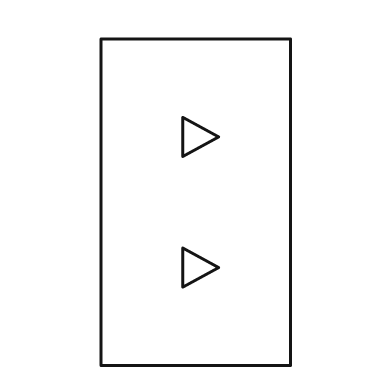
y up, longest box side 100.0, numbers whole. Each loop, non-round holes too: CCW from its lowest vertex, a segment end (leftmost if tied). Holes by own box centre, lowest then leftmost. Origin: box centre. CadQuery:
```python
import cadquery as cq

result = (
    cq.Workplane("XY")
    .moveTo(-29.0, -50.0)
    .lineTo(29.0, -50.0)
    .lineTo(29.0, 50.0)
    .lineTo(-29.0, 50.0)
    .close()
    .moveTo(-4.0, -26.0)
    .lineTo(7.0, -20.0)
    .lineTo(-4.0, -14.0)
    .close()
    .moveTo(-4.0, 14.0)
    .lineTo(7.0, 20.0)
    .lineTo(-4.0, 26.0)
    .close()
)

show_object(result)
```